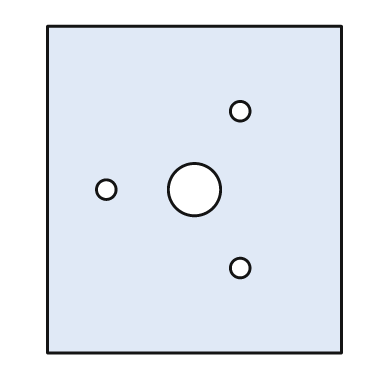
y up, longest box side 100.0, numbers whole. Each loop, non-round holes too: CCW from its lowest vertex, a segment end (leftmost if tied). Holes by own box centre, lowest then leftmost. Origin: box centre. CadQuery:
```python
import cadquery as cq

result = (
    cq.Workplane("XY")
    .moveTo(-45.0, -50.0)
    .lineTo(45.0, -50.0)
    .lineTo(45.0, 50.0)
    .lineTo(-45.0, 50.0)
    .close()
    .moveTo(14.0, -24.0)
    .circle(3.0)
    .moveTo(-27.0, 0.0)
    .circle(3.0)
    .moveTo(0.0, 0.0)
    .circle(8.0)
    .moveTo(14.0, 24.0)
    .circle(3.0)
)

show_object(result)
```